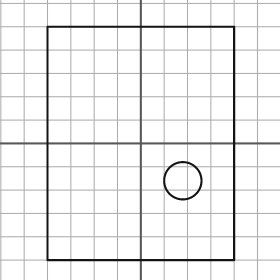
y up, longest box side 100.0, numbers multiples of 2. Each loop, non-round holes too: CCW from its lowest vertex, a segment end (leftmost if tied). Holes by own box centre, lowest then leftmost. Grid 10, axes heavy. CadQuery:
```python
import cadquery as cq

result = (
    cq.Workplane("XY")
    .moveTo(-40.0, -50.0)
    .lineTo(40.0, -50.0)
    .lineTo(40.0, 50.0)
    .lineTo(-40.0, 50.0)
    .close()
    .moveTo(18.0, -16.0)
    .circle(8.0)
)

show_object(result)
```